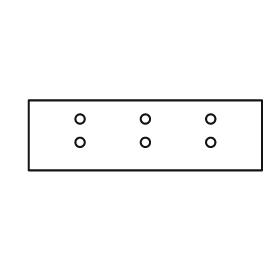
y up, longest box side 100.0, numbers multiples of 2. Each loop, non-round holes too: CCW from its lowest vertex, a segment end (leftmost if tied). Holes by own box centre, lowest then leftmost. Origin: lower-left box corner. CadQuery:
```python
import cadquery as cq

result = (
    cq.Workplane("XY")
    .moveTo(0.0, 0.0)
    .lineTo(100.0, 0.0)
    .lineTo(100.0, 30.0)
    .lineTo(0.0, 30.0)
    .close()
    .moveTo(22.0, 12.0)
    .circle(2.0)
    .moveTo(50.0, 12.0)
    .circle(2.0)
    .moveTo(78.0, 12.0)
    .circle(2.0)
    .moveTo(22.0, 22.0)
    .circle(2.0)
    .moveTo(50.0, 22.0)
    .circle(2.0)
    .moveTo(78.0, 22.0)
    .circle(2.0)
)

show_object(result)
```